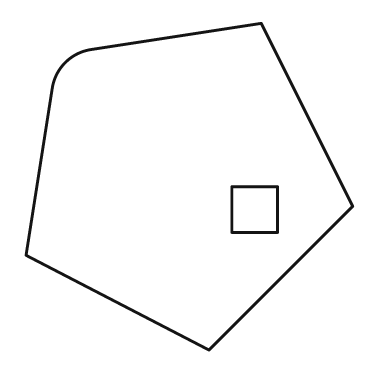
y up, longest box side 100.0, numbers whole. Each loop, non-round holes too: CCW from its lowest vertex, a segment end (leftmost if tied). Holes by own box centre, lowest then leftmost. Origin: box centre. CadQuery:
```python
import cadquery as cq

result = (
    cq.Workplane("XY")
    .moveTo(6.0, -50.0)
    .lineTo(50.0, -6.0)
    .lineTo(22.0, 50.0)
    .lineTo(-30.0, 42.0)
    .threePointArc((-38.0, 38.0), (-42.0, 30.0))
    .lineTo(-50.0, -21.0)
    .close()
    .moveTo(13.0, -14.0)
    .lineTo(27.0, -14.0)
    .lineTo(27.0, 0.0)
    .lineTo(13.0, 0.0)
    .close()
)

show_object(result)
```